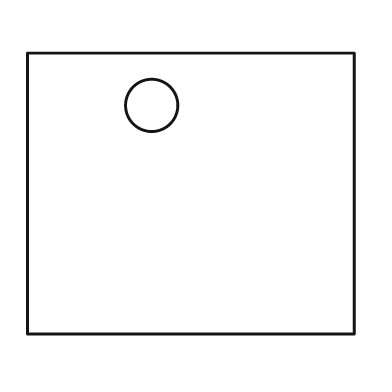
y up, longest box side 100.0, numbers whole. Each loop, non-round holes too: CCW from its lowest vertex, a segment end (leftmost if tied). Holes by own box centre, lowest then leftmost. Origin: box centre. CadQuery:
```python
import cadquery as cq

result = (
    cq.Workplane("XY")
    .moveTo(-50.0, -43.0)
    .lineTo(50.0, -43.0)
    .lineTo(50.0, 43.0)
    .lineTo(-50.0, 43.0)
    .close()
    .moveTo(-12.0, 27.0)
    .circle(8.0)
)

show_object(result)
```